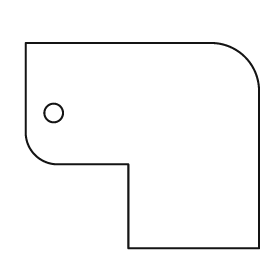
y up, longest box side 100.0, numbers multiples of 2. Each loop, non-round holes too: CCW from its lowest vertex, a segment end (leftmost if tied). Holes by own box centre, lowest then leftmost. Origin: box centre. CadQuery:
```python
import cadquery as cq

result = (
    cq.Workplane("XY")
    .moveTo(-6.0, -44.0)
    .lineTo(50.0, -44.0)
    .lineTo(50.0, 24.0)
    .threePointArc((44.0, 38.0), (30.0, 44.0))
    .lineTo(-50.0, 44.0)
    .lineTo(-50.0, 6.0)
    .threePointArc((-46.0, -4.0), (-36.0, -8.0))
    .lineTo(-6.0, -8.0)
    .close()
    .moveTo(-38.0, 14.0)
    .circle(4.0)
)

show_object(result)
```